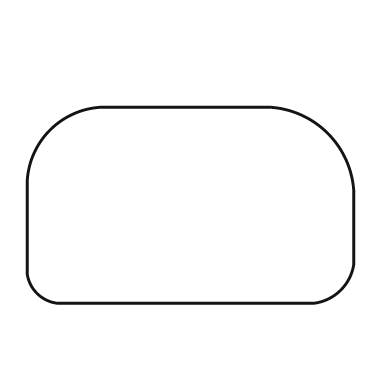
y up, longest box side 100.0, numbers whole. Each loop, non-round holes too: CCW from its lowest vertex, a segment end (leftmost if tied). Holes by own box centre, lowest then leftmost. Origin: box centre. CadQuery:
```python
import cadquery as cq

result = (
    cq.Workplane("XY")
    .moveTo(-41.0, -30.0)
    .lineTo(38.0, -30.0)
    .threePointArc((46.0, -26.0), (50.0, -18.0))
    .lineTo(50.0, 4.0)
    .threePointArc((42.0, 22.0), (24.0, 30.0))
    .lineTo(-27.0, 30.0)
    .threePointArc((-43.0, 23.0), (-50.0, 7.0))
    .lineTo(-50.0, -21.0)
    .threePointArc((-47.0, -27.0), (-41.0, -30.0))
    .close()
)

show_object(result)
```